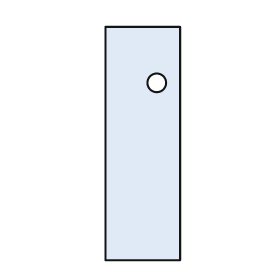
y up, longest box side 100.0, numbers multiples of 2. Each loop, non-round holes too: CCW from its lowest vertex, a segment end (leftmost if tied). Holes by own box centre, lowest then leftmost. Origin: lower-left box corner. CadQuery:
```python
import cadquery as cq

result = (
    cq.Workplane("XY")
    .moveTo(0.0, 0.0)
    .lineTo(32.0, 0.0)
    .lineTo(32.0, 100.0)
    .lineTo(0.0, 100.0)
    .close()
    .moveTo(22.0, 76.0)
    .circle(4.0)
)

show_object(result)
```